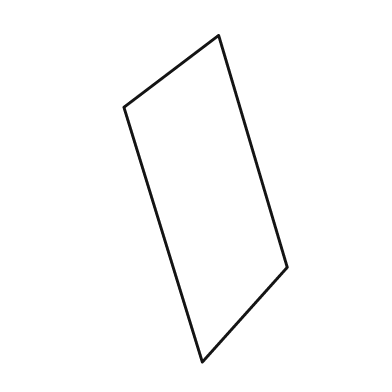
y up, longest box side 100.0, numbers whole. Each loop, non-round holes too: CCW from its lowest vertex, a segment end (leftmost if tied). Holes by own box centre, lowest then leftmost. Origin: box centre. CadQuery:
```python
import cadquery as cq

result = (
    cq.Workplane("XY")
    .moveTo(-1.0, -50.0)
    .lineTo(25.0, -21.0)
    .lineTo(4.0, 50.0)
    .lineTo(-25.0, 28.0)
    .close()
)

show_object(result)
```